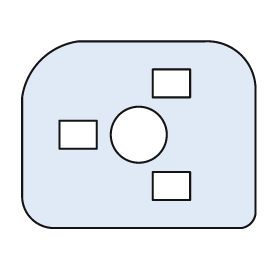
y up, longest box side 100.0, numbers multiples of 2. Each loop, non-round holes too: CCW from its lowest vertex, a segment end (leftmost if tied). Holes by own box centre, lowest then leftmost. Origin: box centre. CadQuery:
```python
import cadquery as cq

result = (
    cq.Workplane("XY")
    .moveTo(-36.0, -40.0)
    .lineTo(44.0, -40.0)
    .threePointArc((48.0, -38.0), (50.0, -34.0))
    .lineTo(50.0, 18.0)
    .threePointArc((44.0, 34.0), (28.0, 40.0))
    .lineTo(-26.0, 40.0)
    .threePointArc((-42.0, 32.0), (-50.0, 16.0))
    .lineTo(-50.0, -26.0)
    .threePointArc((-46.0, -36.0), (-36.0, -40.0))
    .close()
    .moveTo(6.0, -28.0)
    .lineTo(22.0, -28.0)
    .lineTo(22.0, -16.0)
    .lineTo(6.0, -16.0)
    .close()
    .moveTo(-34.0, -6.0)
    .lineTo(-18.0, -6.0)
    .lineTo(-18.0, 6.0)
    .lineTo(-34.0, 6.0)
    .close()
    .moveTo(0.0, 0.0)
    .circle(12.0)
    .moveTo(6.0, 16.0)
    .lineTo(22.0, 16.0)
    .lineTo(22.0, 28.0)
    .lineTo(6.0, 28.0)
    .close()
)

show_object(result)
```